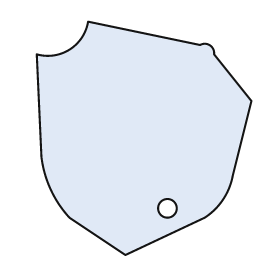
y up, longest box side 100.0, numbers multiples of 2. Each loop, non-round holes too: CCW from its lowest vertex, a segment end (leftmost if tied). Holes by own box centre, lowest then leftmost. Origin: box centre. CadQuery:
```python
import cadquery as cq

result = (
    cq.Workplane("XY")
    .moveTo(-8.0, -50.0)
    .lineTo(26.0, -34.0)
    .threePointArc((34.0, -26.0), (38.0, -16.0))
    .lineTo(46.0, 16.0)
    .lineTo(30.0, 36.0)
    .threePointArc((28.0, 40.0), (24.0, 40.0))
    .lineTo(-24.0, 50.0)
    .threePointArc((-32.0, 38.0), (-46.0, 36.0))
    .lineTo(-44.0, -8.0)
    .threePointArc((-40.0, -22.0), (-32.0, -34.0))
    .close()
    .moveTo(10.0, -30.0)
    .circle(4.0)
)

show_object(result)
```